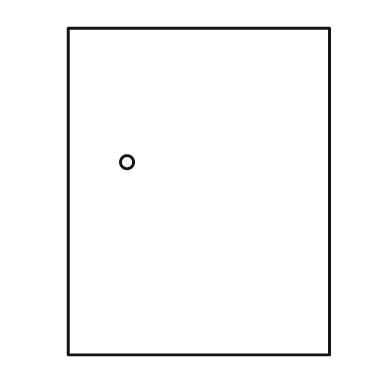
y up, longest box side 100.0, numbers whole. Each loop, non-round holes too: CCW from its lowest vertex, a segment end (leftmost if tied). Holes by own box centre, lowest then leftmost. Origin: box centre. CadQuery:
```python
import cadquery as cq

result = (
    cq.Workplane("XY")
    .moveTo(-40.0, -50.0)
    .lineTo(40.0, -50.0)
    .lineTo(40.0, 50.0)
    .lineTo(-40.0, 50.0)
    .close()
    .moveTo(-22.0, 9.0)
    .circle(2.0)
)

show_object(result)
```